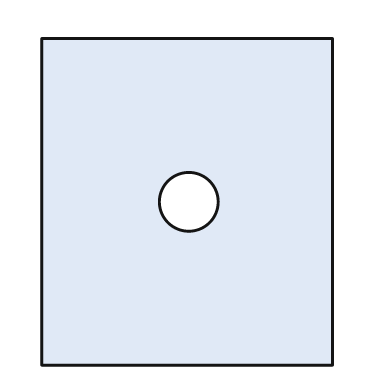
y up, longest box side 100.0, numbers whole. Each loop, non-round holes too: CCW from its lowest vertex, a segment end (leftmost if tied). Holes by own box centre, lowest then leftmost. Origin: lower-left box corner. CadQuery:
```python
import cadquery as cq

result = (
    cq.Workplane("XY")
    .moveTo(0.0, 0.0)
    .lineTo(89.0, 0.0)
    .lineTo(89.0, 100.0)
    .lineTo(0.0, 100.0)
    .close()
    .moveTo(45.0, 50.0)
    .circle(9.0)
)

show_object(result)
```